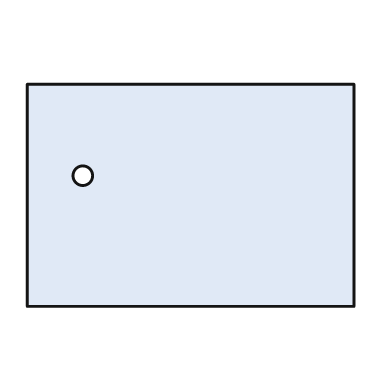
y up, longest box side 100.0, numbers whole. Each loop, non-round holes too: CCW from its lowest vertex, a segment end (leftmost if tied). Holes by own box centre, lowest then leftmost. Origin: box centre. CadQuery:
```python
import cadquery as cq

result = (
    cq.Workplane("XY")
    .moveTo(-50.0, -34.0)
    .lineTo(50.0, -34.0)
    .lineTo(50.0, 34.0)
    .lineTo(-50.0, 34.0)
    .close()
    .moveTo(-33.0, 6.0)
    .circle(3.0)
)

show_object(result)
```